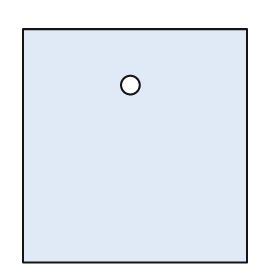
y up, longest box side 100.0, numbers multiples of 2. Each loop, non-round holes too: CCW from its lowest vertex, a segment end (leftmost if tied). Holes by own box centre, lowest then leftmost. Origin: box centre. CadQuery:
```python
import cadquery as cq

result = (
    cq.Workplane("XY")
    .moveTo(-48.0, -50.0)
    .lineTo(48.0, -50.0)
    .lineTo(48.0, 50.0)
    .lineTo(-48.0, 50.0)
    .close()
    .moveTo(-2.0, 26.0)
    .circle(4.0)
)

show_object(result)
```